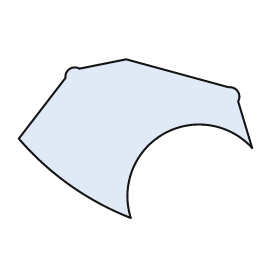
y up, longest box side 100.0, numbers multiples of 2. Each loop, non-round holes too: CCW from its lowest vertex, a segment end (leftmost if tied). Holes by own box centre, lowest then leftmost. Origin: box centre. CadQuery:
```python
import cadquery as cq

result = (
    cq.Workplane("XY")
    .moveTo(-2.0, -34.0)
    .threePointArc((12.0, 2.0), (50.0, -4.0))
    .lineTo(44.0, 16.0)
    .threePointArc((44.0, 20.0), (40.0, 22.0))
    .lineTo(-4.0, 34.0)
    .lineTo(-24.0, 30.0)
    .threePointArc((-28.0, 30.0), (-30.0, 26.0))
    .lineTo(-50.0, 0.0)
    .threePointArc((-28.0, -20.0), (-2.0, -34.0))
    .close()
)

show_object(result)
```